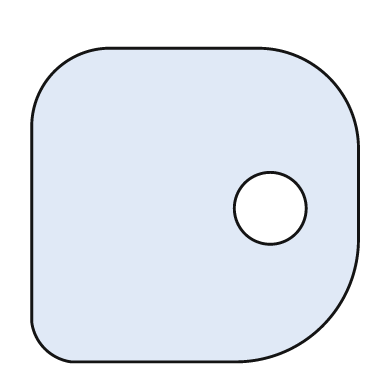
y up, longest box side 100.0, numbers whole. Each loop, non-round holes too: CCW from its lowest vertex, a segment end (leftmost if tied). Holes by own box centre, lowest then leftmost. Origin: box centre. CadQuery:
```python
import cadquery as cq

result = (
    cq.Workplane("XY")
    .moveTo(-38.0, -48.0)
    .lineTo(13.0, -48.0)
    .threePointArc((39.0, -37.0), (50.0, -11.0))
    .lineTo(50.0, 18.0)
    .threePointArc((41.0, 39.0), (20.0, 48.0))
    .lineTo(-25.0, 48.0)
    .threePointArc((-43.0, 41.0), (-50.0, 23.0))
    .lineTo(-50.0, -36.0)
    .threePointArc((-46.0, -44.0), (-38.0, -48.0))
    .close()
    .moveTo(23.0, -1.0)
    .circle(11.0)
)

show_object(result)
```